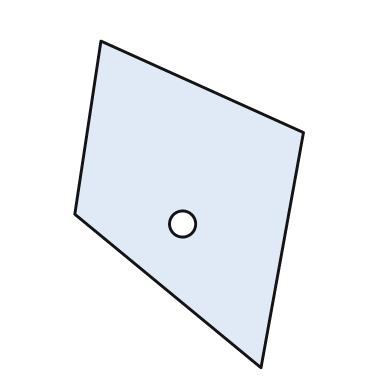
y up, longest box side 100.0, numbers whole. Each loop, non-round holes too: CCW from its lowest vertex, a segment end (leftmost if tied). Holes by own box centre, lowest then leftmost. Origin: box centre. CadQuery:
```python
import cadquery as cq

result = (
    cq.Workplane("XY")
    .moveTo(22.0, -50.0)
    .lineTo(35.0, 22.0)
    .lineTo(-27.0, 50.0)
    .lineTo(-35.0, -3.0)
    .close()
    .moveTo(-2.0, -6.0)
    .circle(4.0)
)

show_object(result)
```